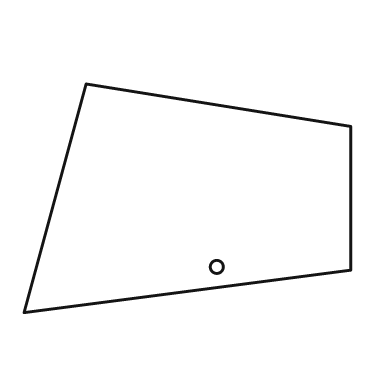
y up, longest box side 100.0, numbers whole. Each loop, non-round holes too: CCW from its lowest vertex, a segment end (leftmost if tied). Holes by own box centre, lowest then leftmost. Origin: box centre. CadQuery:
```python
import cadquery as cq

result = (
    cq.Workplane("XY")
    .moveTo(-50.0, -35.0)
    .lineTo(50.0, -22.0)
    .lineTo(50.0, 22.0)
    .lineTo(-31.0, 35.0)
    .close()
    .moveTo(9.0, -21.0)
    .circle(2.0)
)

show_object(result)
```